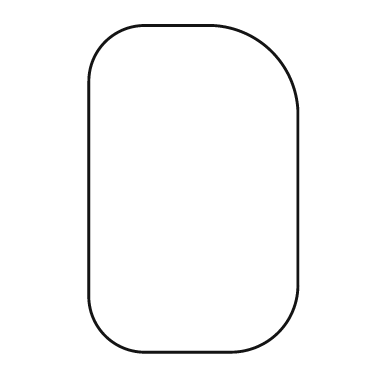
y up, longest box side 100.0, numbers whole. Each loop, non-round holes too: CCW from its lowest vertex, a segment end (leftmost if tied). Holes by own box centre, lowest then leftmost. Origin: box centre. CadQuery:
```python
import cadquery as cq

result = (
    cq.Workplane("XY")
    .moveTo(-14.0, -50.0)
    .lineTo(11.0, -50.0)
    .threePointArc((26.0, -44.0), (32.0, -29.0))
    .lineTo(32.0, 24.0)
    .threePointArc((24.0, 42.0), (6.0, 50.0))
    .lineTo(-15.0, 50.0)
    .threePointArc((-27.0, 45.0), (-32.0, 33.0))
    .lineTo(-32.0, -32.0)
    .threePointArc((-27.0, -45.0), (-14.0, -50.0))
    .close()
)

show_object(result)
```